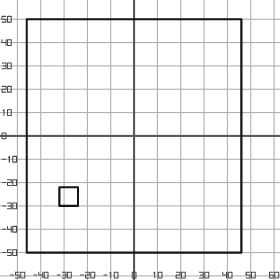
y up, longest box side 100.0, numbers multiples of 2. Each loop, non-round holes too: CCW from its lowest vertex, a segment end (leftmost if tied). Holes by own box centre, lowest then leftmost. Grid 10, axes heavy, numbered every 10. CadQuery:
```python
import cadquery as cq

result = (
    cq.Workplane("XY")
    .moveTo(-46.0, -50.0)
    .lineTo(46.0, -50.0)
    .lineTo(46.0, 50.0)
    .lineTo(-46.0, 50.0)
    .close()
    .moveTo(-32.0, -30.0)
    .lineTo(-24.0, -30.0)
    .lineTo(-24.0, -22.0)
    .lineTo(-32.0, -22.0)
    .close()
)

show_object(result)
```